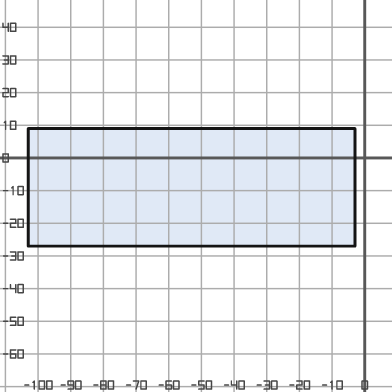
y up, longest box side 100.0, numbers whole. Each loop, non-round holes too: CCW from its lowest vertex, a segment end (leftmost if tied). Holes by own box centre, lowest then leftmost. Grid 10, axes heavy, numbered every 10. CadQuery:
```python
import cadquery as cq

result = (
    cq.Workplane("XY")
    .moveTo(-103.0, -27.0)
    .lineTo(-3.0, -27.0)
    .lineTo(-3.0, 9.0)
    .lineTo(-103.0, 9.0)
    .close()
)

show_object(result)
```